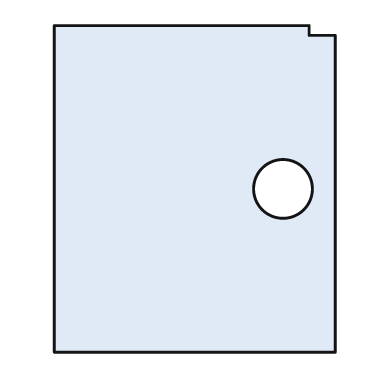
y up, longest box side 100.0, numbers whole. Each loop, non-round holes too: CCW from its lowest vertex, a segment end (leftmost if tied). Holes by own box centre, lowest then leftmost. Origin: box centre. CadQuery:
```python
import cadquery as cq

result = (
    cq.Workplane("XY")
    .moveTo(-43.0, -50.0)
    .lineTo(43.0, -50.0)
    .lineTo(43.0, 47.0)
    .lineTo(35.0, 47.0)
    .lineTo(35.0, 50.0)
    .lineTo(-43.0, 50.0)
    .close()
    .moveTo(27.0, 0.0)
    .circle(9.0)
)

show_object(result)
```